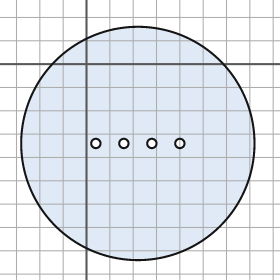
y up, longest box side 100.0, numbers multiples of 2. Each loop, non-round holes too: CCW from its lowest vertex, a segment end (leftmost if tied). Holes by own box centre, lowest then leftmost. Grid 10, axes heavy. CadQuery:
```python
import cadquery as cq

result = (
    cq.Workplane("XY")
    .moveTo(22.0, -34.0)
    .circle(50.0)
    .moveTo(4.0, -34.0)
    .circle(2.0)
    .moveTo(16.0, -34.0)
    .circle(2.0)
    .moveTo(28.0, -34.0)
    .circle(2.0)
    .moveTo(40.0, -34.0)
    .circle(2.0)
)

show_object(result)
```